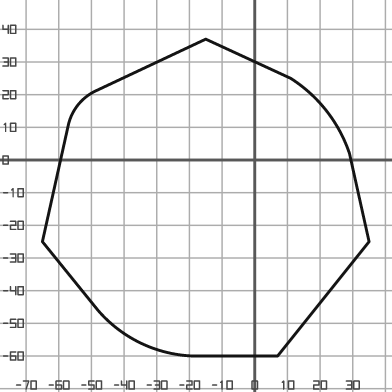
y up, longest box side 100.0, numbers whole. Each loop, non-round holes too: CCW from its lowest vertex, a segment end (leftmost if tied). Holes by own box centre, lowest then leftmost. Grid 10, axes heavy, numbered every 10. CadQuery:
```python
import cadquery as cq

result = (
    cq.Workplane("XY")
    .moveTo(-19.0, -60.0)
    .lineTo(7.0, -60.0)
    .lineTo(35.0, -25.0)
    .lineTo(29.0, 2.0)
    .threePointArc((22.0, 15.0), (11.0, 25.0))
    .lineTo(-15.0, 37.0)
    .lineTo(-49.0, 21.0)
    .threePointArc((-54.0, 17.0), (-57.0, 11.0))
    .lineTo(-65.0, -25.0)
    .lineTo(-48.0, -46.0)
    .threePointArc((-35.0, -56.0), (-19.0, -60.0))
    .close()
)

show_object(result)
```